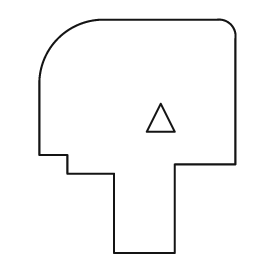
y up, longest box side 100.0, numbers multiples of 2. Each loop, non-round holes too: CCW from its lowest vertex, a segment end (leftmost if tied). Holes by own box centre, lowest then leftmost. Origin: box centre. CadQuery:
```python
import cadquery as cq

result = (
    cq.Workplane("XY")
    .moveTo(-10.0, -50.0)
    .lineTo(16.0, -50.0)
    .lineTo(16.0, -12.0)
    .lineTo(42.0, -12.0)
    .lineTo(42.0, 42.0)
    .threePointArc((40.0, 48.0), (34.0, 50.0))
    .lineTo(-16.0, 50.0)
    .threePointArc((-34.0, 42.0), (-42.0, 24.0))
    .lineTo(-42.0, -8.0)
    .lineTo(-30.0, -8.0)
    .lineTo(-30.0, -16.0)
    .lineTo(-10.0, -16.0)
    .close()
    .moveTo(4.0, 2.0)
    .lineTo(16.0, 2.0)
    .lineTo(10.0, 14.0)
    .close()
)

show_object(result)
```